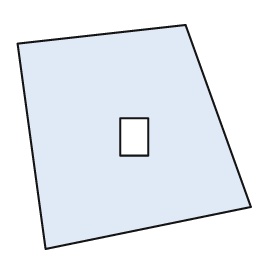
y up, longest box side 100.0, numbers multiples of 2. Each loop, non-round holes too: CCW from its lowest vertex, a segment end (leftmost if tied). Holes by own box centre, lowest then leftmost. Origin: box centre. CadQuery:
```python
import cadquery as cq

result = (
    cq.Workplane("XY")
    .moveTo(-38.0, -48.0)
    .lineTo(50.0, -30.0)
    .lineTo(22.0, 48.0)
    .lineTo(-50.0, 40.0)
    .close()
    .moveTo(-6.0, -8.0)
    .lineTo(6.0, -8.0)
    .lineTo(6.0, 8.0)
    .lineTo(-6.0, 8.0)
    .close()
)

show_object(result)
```